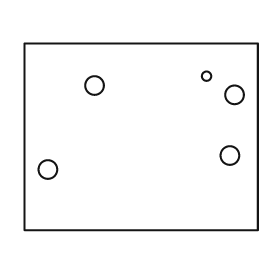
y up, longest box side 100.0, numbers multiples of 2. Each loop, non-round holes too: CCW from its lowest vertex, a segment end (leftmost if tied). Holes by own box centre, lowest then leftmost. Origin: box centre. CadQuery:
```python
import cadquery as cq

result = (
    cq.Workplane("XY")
    .moveTo(-50.0, -40.0)
    .lineTo(50.0, -40.0)
    .lineTo(50.0, 40.0)
    .lineTo(-50.0, 40.0)
    .close()
    .moveTo(-40.0, -14.0)
    .circle(4.0)
    .moveTo(38.0, -8.0)
    .circle(4.0)
    .moveTo(40.0, 18.0)
    .circle(4.0)
    .moveTo(-20.0, 22.0)
    .circle(4.0)
    .moveTo(28.0, 26.0)
    .circle(2.0)
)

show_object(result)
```